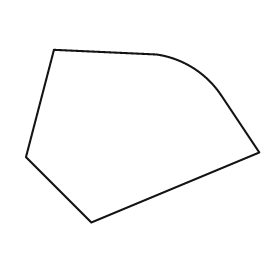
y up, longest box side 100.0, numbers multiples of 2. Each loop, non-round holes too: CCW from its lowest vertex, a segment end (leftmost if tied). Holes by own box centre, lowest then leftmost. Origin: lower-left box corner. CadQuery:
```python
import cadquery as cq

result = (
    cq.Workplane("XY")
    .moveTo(28.0, 0.0)
    .lineTo(100.0, 30.0)
    .lineTo(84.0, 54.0)
    .threePointArc((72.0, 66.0), (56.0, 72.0))
    .lineTo(12.0, 74.0)
    .lineTo(0.0, 28.0)
    .close()
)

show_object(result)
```